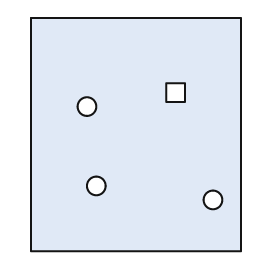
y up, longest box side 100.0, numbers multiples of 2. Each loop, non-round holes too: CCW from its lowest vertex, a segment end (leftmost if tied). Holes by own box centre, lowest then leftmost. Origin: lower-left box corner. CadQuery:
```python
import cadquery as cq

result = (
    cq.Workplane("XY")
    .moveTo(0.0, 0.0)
    .lineTo(90.0, 0.0)
    .lineTo(90.0, 100.0)
    .lineTo(0.0, 100.0)
    .close()
    .moveTo(78.0, 22.0)
    .circle(4.0)
    .moveTo(28.0, 28.0)
    .circle(4.0)
    .moveTo(24.0, 62.0)
    .circle(4.0)
    .moveTo(58.0, 64.0)
    .lineTo(66.0, 64.0)
    .lineTo(66.0, 72.0)
    .lineTo(58.0, 72.0)
    .close()
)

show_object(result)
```